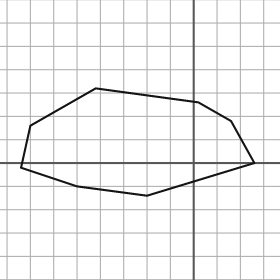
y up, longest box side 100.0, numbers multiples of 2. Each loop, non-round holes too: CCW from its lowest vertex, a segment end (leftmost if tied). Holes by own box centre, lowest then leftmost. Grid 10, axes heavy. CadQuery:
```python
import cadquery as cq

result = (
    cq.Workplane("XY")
    .moveTo(-20.0, -14.0)
    .lineTo(26.0, 0.0)
    .lineTo(16.0, 18.0)
    .lineTo(2.0, 26.0)
    .lineTo(-42.0, 32.0)
    .lineTo(-70.0, 16.0)
    .lineTo(-74.0, -2.0)
    .lineTo(-50.0, -10.0)
    .close()
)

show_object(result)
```